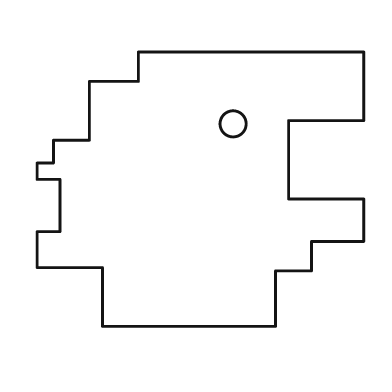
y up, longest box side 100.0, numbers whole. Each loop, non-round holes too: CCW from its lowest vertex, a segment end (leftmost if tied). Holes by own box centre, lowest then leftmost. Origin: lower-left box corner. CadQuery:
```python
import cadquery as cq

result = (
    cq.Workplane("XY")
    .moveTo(20.0, 0.0)
    .lineTo(73.0, 0.0)
    .lineTo(73.0, 17.0)
    .lineTo(84.0, 17.0)
    .lineTo(84.0, 26.0)
    .lineTo(100.0, 26.0)
    .lineTo(100.0, 39.0)
    .lineTo(77.0, 39.0)
    .lineTo(77.0, 63.0)
    .lineTo(100.0, 63.0)
    .lineTo(100.0, 84.0)
    .lineTo(31.0, 84.0)
    .lineTo(31.0, 75.0)
    .lineTo(16.0, 75.0)
    .lineTo(16.0, 57.0)
    .lineTo(5.0, 57.0)
    .lineTo(5.0, 50.0)
    .lineTo(0.0, 50.0)
    .lineTo(0.0, 45.0)
    .lineTo(7.0, 45.0)
    .lineTo(7.0, 29.0)
    .lineTo(0.0, 29.0)
    .lineTo(0.0, 18.0)
    .lineTo(20.0, 18.0)
    .close()
    .moveTo(60.0, 62.0)
    .circle(4.0)
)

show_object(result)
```